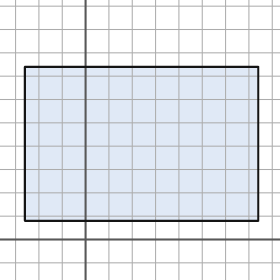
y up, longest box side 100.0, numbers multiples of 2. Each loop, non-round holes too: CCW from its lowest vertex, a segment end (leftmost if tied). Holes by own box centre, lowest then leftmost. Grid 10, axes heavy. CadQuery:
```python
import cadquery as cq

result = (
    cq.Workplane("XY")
    .moveTo(-26.0, 8.0)
    .lineTo(74.0, 8.0)
    .lineTo(74.0, 74.0)
    .lineTo(-26.0, 74.0)
    .close()
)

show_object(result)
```